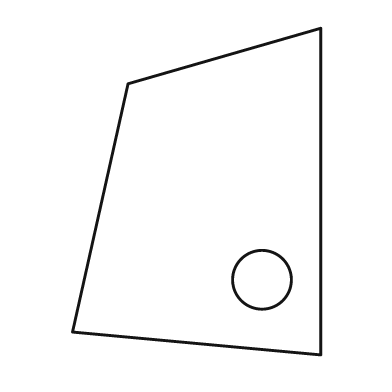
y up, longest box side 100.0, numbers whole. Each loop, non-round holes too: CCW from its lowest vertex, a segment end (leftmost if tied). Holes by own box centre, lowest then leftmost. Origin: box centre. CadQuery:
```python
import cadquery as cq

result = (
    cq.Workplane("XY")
    .moveTo(38.0, -50.0)
    .lineTo(38.0, 50.0)
    .lineTo(-21.0, 33.0)
    .lineTo(-38.0, -43.0)
    .close()
    .moveTo(20.0, -27.0)
    .circle(9.0)
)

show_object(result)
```